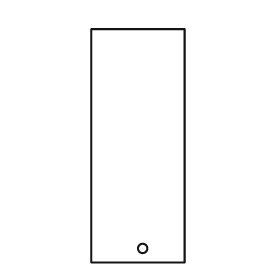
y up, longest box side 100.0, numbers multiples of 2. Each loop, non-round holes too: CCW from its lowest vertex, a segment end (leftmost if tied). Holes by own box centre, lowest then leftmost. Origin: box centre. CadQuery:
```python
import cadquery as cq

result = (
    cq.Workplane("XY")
    .moveTo(-20.0, -50.0)
    .lineTo(20.0, -50.0)
    .lineTo(20.0, 50.0)
    .lineTo(-20.0, 50.0)
    .close()
    .moveTo(2.0, -44.0)
    .circle(2.0)
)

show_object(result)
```